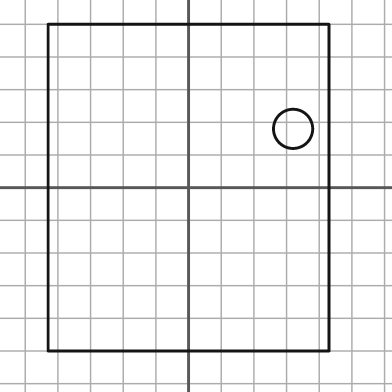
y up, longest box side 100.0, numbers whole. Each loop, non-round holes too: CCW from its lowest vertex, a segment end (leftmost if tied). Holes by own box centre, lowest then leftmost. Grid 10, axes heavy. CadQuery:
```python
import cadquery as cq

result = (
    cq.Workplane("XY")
    .moveTo(-43.0, -50.0)
    .lineTo(43.0, -50.0)
    .lineTo(43.0, 50.0)
    .lineTo(-43.0, 50.0)
    .close()
    .moveTo(32.0, 18.0)
    .circle(6.0)
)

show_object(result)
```